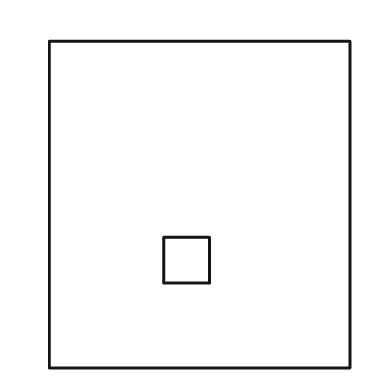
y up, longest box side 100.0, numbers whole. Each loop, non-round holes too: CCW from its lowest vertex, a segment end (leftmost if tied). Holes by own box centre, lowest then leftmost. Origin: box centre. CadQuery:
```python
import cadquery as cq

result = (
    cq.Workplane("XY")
    .moveTo(-46.0, -50.0)
    .lineTo(46.0, -50.0)
    .lineTo(46.0, 50.0)
    .lineTo(-46.0, 50.0)
    .close()
    .moveTo(-11.0, -24.0)
    .lineTo(3.0, -24.0)
    .lineTo(3.0, -10.0)
    .lineTo(-11.0, -10.0)
    .close()
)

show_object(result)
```